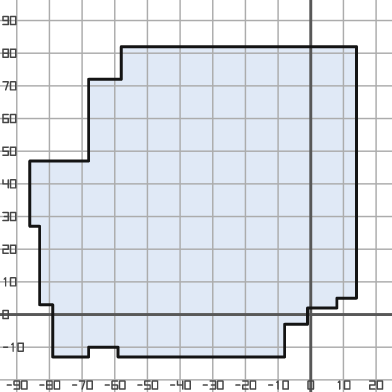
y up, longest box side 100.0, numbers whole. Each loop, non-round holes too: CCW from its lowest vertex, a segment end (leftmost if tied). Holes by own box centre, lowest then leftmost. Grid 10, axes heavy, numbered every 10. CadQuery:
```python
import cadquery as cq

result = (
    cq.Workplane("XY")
    .moveTo(-79.0, -13.0)
    .lineTo(-68.0, -13.0)
    .lineTo(-68.0, -10.0)
    .lineTo(-59.0, -10.0)
    .lineTo(-59.0, -13.0)
    .lineTo(-8.0, -13.0)
    .lineTo(-8.0, -3.0)
    .lineTo(-1.0, -3.0)
    .lineTo(-1.0, 2.0)
    .lineTo(8.0, 2.0)
    .lineTo(8.0, 5.0)
    .lineTo(14.0, 5.0)
    .lineTo(14.0, 82.0)
    .lineTo(-58.0, 82.0)
    .lineTo(-58.0, 72.0)
    .lineTo(-68.0, 72.0)
    .lineTo(-68.0, 47.0)
    .lineTo(-86.0, 47.0)
    .lineTo(-86.0, 27.0)
    .lineTo(-83.0, 27.0)
    .lineTo(-83.0, 3.0)
    .lineTo(-79.0, 3.0)
    .close()
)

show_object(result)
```